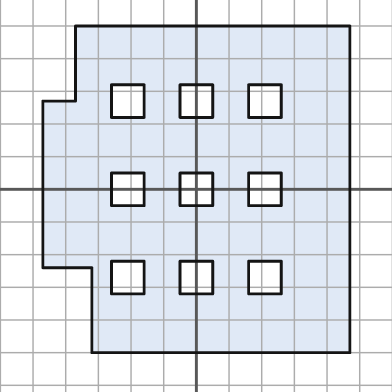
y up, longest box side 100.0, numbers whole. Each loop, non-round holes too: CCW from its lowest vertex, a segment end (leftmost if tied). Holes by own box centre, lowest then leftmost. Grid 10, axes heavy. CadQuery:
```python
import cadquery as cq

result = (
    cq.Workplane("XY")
    .moveTo(-32.0, -50.0)
    .lineTo(47.0, -50.0)
    .lineTo(47.0, 50.0)
    .lineTo(-37.0, 50.0)
    .lineTo(-37.0, 27.0)
    .lineTo(-47.0, 27.0)
    .lineTo(-47.0, -24.0)
    .lineTo(-32.0, -24.0)
    .close()
    .moveTo(-26.0, -32.0)
    .lineTo(-16.0, -32.0)
    .lineTo(-16.0, -22.0)
    .lineTo(-26.0, -22.0)
    .close()
    .moveTo(-5.0, -32.0)
    .lineTo(5.0, -32.0)
    .lineTo(5.0, -22.0)
    .lineTo(-5.0, -22.0)
    .close()
    .moveTo(16.0, -32.0)
    .lineTo(26.0, -32.0)
    .lineTo(26.0, -22.0)
    .lineTo(16.0, -22.0)
    .close()
    .moveTo(-26.0, -5.0)
    .lineTo(-16.0, -5.0)
    .lineTo(-16.0, 5.0)
    .lineTo(-26.0, 5.0)
    .close()
    .moveTo(-5.0, -5.0)
    .lineTo(5.0, -5.0)
    .lineTo(5.0, 5.0)
    .lineTo(-5.0, 5.0)
    .close()
    .moveTo(16.0, -5.0)
    .lineTo(26.0, -5.0)
    .lineTo(26.0, 5.0)
    .lineTo(16.0, 5.0)
    .close()
    .moveTo(-26.0, 22.0)
    .lineTo(-16.0, 22.0)
    .lineTo(-16.0, 32.0)
    .lineTo(-26.0, 32.0)
    .close()
    .moveTo(-5.0, 22.0)
    .lineTo(5.0, 22.0)
    .lineTo(5.0, 32.0)
    .lineTo(-5.0, 32.0)
    .close()
    .moveTo(16.0, 22.0)
    .lineTo(26.0, 22.0)
    .lineTo(26.0, 32.0)
    .lineTo(16.0, 32.0)
    .close()
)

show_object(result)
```